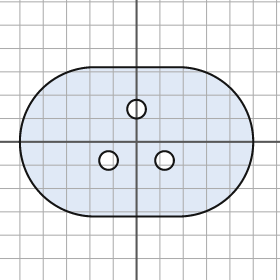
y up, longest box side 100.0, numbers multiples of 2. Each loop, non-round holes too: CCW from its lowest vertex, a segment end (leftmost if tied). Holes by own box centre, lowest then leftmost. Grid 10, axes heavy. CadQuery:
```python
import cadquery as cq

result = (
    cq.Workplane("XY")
    .moveTo(-18.0, -32.0)
    .lineTo(18.0, -32.0)
    .threePointArc((50.0, 0.0), (18.0, 32.0))
    .lineTo(-18.0, 32.0)
    .threePointArc((-50.0, 0.0), (-18.0, -32.0))
    .close()
    .moveTo(-12.0, -8.0)
    .circle(4.0)
    .moveTo(12.0, -8.0)
    .circle(4.0)
    .moveTo(0.0, 14.0)
    .circle(4.0)
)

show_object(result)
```